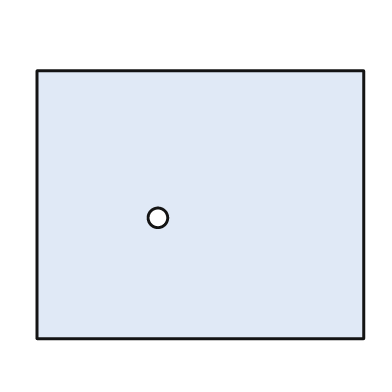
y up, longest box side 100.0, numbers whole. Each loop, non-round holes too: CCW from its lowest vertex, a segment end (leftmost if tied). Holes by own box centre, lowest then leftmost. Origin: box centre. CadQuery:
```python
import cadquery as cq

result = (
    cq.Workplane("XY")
    .moveTo(-50.0, -41.0)
    .lineTo(50.0, -41.0)
    .lineTo(50.0, 41.0)
    .lineTo(-50.0, 41.0)
    .close()
    .moveTo(-13.0, -4.0)
    .circle(3.0)
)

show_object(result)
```